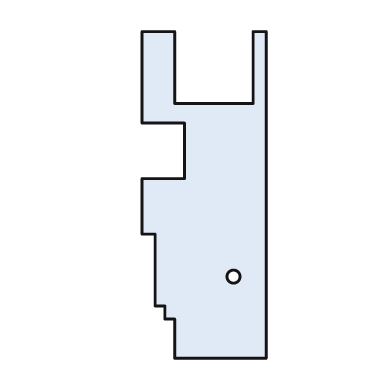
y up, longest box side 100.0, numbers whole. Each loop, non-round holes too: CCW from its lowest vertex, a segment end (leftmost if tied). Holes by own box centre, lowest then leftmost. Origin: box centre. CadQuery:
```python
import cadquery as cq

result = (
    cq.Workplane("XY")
    .moveTo(-9.0, -50.0)
    .lineTo(19.0, -50.0)
    .lineTo(19.0, 50.0)
    .lineTo(15.0, 50.0)
    .lineTo(15.0, 28.0)
    .lineTo(-9.0, 28.0)
    .lineTo(-9.0, 50.0)
    .lineTo(-19.0, 50.0)
    .lineTo(-19.0, 22.0)
    .lineTo(-6.0, 22.0)
    .lineTo(-6.0, 5.0)
    .lineTo(-19.0, 5.0)
    .lineTo(-19.0, -12.0)
    .lineTo(-15.0, -12.0)
    .lineTo(-15.0, -34.0)
    .lineTo(-12.0, -34.0)
    .lineTo(-12.0, -38.0)
    .lineTo(-9.0, -38.0)
    .close()
    .moveTo(9.0, -25.0)
    .circle(2.0)
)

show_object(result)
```